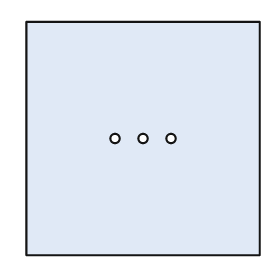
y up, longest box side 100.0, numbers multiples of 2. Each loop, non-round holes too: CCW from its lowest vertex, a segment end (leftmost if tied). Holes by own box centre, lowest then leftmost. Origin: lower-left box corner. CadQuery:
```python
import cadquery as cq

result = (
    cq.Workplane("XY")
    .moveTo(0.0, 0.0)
    .lineTo(100.0, 0.0)
    .lineTo(100.0, 100.0)
    .lineTo(0.0, 100.0)
    .close()
    .moveTo(38.0, 50.0)
    .circle(2.0)
    .moveTo(50.0, 50.0)
    .circle(2.0)
    .moveTo(62.0, 50.0)
    .circle(2.0)
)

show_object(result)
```